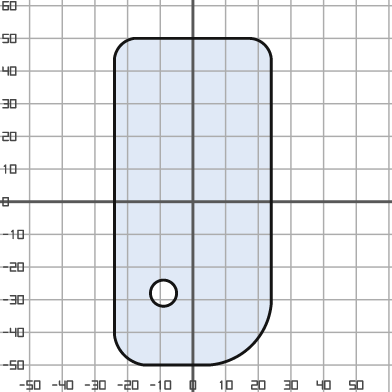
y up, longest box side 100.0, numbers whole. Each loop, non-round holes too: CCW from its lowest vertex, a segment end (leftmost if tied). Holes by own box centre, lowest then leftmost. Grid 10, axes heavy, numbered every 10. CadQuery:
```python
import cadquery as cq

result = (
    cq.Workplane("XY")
    .moveTo(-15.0, -50.0)
    .lineTo(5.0, -50.0)
    .threePointArc((18.0, -44.0), (24.0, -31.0))
    .lineTo(24.0, 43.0)
    .threePointArc((22.0, 48.0), (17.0, 50.0))
    .lineTo(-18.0, 50.0)
    .threePointArc((-22.0, 48.0), (-24.0, 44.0))
    .lineTo(-24.0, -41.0)
    .threePointArc((-21.0, -47.0), (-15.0, -50.0))
    .close()
    .moveTo(-9.0, -28.0)
    .circle(4.0)
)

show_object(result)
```